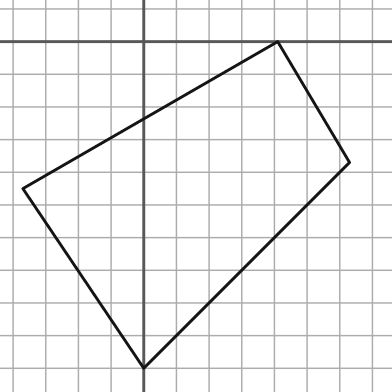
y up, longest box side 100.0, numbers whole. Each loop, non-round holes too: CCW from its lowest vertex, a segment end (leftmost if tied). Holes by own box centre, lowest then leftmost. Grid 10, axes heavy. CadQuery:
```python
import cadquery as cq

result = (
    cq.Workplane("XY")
    .moveTo(0.0, -100.0)
    .lineTo(63.0, -37.0)
    .lineTo(41.0, 0.0)
    .lineTo(-37.0, -45.0)
    .close()
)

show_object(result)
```